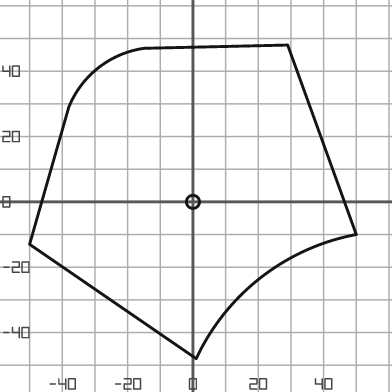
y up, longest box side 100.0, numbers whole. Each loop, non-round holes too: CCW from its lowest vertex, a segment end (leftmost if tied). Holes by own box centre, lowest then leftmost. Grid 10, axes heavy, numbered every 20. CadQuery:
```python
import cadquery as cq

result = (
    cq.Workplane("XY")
    .moveTo(1.0, -48.0)
    .threePointArc((21.0, -23.0), (50.0, -10.0))
    .lineTo(29.0, 48.0)
    .lineTo(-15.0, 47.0)
    .threePointArc((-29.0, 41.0), (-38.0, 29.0))
    .lineTo(-50.0, -13.0)
    .close()
    .moveTo(0.0, 0.0)
    .circle(2.0)
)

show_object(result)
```